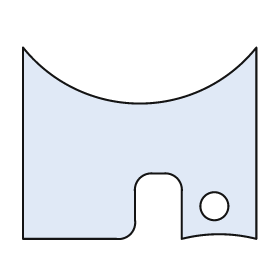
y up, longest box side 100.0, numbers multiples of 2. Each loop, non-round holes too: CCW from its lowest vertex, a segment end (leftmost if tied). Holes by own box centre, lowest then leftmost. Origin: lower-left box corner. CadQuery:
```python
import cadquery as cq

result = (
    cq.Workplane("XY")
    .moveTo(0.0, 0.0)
    .lineTo(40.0, 0.0)
    .threePointArc((46.0, 2.0), (48.0, 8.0))
    .lineTo(48.0, 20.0)
    .threePointArc((50.0, 26.0), (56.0, 28.0))
    .lineTo(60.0, 28.0)
    .threePointArc((66.0, 26.0), (68.0, 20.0))
    .lineTo(68.0, 0.0)
    .threePointArc((84.0, 2.0), (100.0, 0.0))
    .lineTo(100.0, 82.0)
    .threePointArc((50.0, 58.0), (0.0, 82.0))
    .close()
    .moveTo(82.0, 14.0)
    .circle(6.0)
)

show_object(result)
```